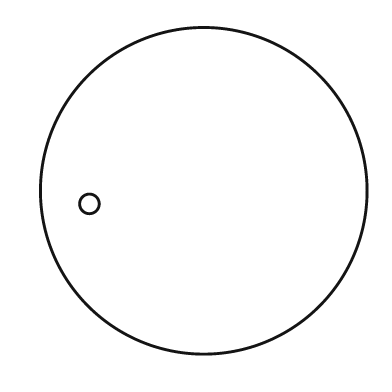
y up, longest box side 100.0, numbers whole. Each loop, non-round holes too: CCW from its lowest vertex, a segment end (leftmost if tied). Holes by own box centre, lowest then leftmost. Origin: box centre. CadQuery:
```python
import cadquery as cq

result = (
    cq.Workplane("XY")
    .moveTo(0.0, 0.0)
    .circle(50.0)
    .moveTo(-35.0, -4.0)
    .circle(3.0)
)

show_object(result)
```